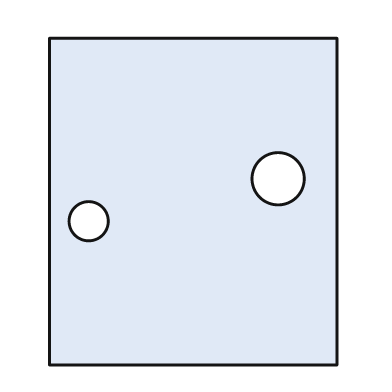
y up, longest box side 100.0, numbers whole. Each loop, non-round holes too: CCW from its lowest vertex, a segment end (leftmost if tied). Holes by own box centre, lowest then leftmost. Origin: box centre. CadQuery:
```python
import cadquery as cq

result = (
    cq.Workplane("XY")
    .moveTo(-44.0, -50.0)
    .lineTo(44.0, -50.0)
    .lineTo(44.0, 50.0)
    .lineTo(-44.0, 50.0)
    .close()
    .moveTo(-32.0, -6.0)
    .circle(6.0)
    .moveTo(26.0, 7.0)
    .circle(8.0)
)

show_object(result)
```